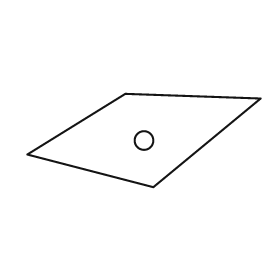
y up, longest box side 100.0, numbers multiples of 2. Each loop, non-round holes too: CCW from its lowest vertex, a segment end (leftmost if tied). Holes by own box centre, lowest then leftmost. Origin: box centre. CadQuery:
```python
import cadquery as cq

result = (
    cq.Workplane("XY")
    .moveTo(4.0, -20.0)
    .lineTo(50.0, 18.0)
    .lineTo(-8.0, 20.0)
    .lineTo(-50.0, -6.0)
    .close()
    .moveTo(0.0, 0.0)
    .circle(4.0)
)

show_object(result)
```